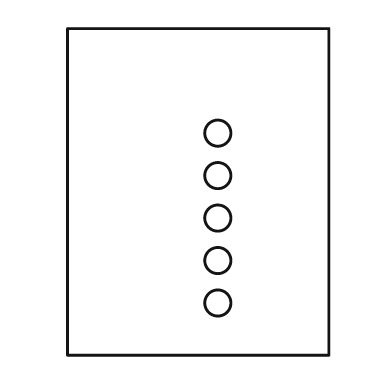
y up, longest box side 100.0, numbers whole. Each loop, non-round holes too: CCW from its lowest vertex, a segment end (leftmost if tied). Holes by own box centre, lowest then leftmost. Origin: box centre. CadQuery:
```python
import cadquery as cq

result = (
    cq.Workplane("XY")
    .moveTo(-40.0, -50.0)
    .lineTo(40.0, -50.0)
    .lineTo(40.0, 50.0)
    .lineTo(-40.0, 50.0)
    .close()
    .moveTo(6.0, -34.0)
    .circle(4.0)
    .moveTo(6.0, -21.0)
    .circle(4.0)
    .moveTo(6.0, -8.0)
    .circle(4.0)
    .moveTo(6.0, 5.0)
    .circle(4.0)
    .moveTo(6.0, 18.0)
    .circle(4.0)
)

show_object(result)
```